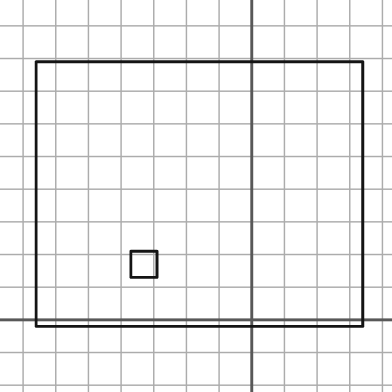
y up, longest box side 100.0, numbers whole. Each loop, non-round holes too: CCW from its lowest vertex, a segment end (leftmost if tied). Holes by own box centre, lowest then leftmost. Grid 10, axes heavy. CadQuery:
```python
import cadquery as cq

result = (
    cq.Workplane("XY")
    .moveTo(-66.0, -2.0)
    .lineTo(34.0, -2.0)
    .lineTo(34.0, 79.0)
    .lineTo(-66.0, 79.0)
    .close()
    .moveTo(-37.0, 13.0)
    .lineTo(-29.0, 13.0)
    .lineTo(-29.0, 21.0)
    .lineTo(-37.0, 21.0)
    .close()
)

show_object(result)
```